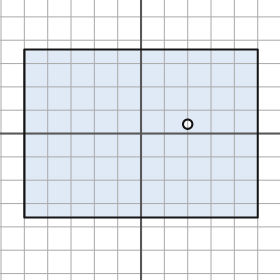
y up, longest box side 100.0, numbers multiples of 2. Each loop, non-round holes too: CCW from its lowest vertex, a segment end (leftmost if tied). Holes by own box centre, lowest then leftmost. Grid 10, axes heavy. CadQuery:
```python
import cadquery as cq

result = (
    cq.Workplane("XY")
    .moveTo(-50.0, -36.0)
    .lineTo(50.0, -36.0)
    .lineTo(50.0, 36.0)
    .lineTo(-50.0, 36.0)
    .close()
    .moveTo(20.0, 4.0)
    .circle(2.0)
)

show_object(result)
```